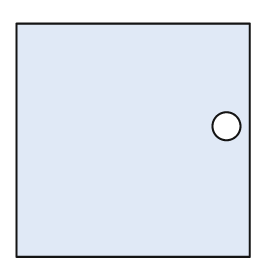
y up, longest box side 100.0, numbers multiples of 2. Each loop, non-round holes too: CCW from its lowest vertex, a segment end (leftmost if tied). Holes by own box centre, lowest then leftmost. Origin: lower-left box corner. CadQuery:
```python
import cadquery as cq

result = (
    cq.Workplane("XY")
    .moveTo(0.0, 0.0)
    .lineTo(100.0, 0.0)
    .lineTo(100.0, 100.0)
    .lineTo(0.0, 100.0)
    .close()
    .moveTo(90.0, 56.0)
    .circle(6.0)
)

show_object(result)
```